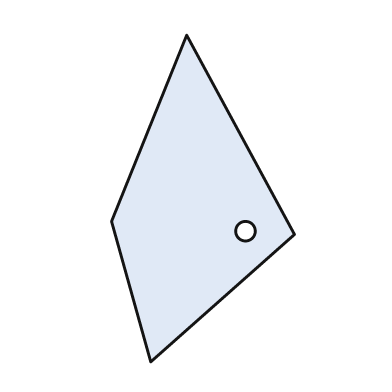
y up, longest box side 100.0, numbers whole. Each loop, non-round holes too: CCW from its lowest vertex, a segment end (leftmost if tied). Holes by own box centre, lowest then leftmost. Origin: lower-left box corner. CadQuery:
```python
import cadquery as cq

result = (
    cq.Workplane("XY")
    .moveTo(12.0, 0.0)
    .lineTo(56.0, 39.0)
    .lineTo(23.0, 100.0)
    .lineTo(0.0, 43.0)
    .close()
    .moveTo(41.0, 40.0)
    .circle(3.0)
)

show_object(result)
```